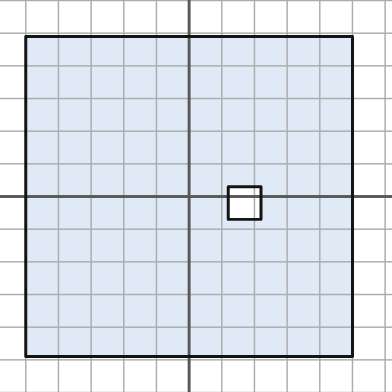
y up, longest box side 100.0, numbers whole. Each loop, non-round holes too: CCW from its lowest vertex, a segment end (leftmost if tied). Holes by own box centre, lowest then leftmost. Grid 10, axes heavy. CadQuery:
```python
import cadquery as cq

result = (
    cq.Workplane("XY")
    .moveTo(-50.0, -49.0)
    .lineTo(50.0, -49.0)
    .lineTo(50.0, 49.0)
    .lineTo(-50.0, 49.0)
    .close()
    .moveTo(12.0, -7.0)
    .lineTo(22.0, -7.0)
    .lineTo(22.0, 3.0)
    .lineTo(12.0, 3.0)
    .close()
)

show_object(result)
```